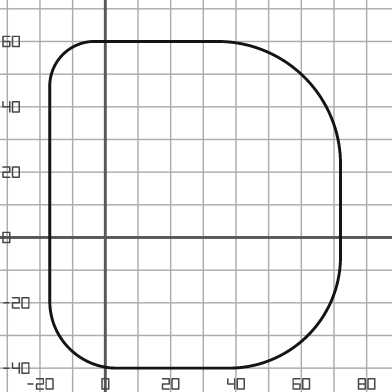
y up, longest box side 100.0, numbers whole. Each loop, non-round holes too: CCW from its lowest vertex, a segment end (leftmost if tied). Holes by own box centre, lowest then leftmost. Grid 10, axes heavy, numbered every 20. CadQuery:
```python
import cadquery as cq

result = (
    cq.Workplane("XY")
    .moveTo(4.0, -40.0)
    .lineTo(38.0, -40.0)
    .threePointArc((62.0, -30.0), (72.0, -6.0))
    .lineTo(72.0, 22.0)
    .threePointArc((61.0, 49.0), (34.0, 60.0))
    .lineTo(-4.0, 60.0)
    .threePointArc((-13.0, 56.0), (-17.0, 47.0))
    .lineTo(-17.0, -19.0)
    .threePointArc((-11.0, -34.0), (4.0, -40.0))
    .close()
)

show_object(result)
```